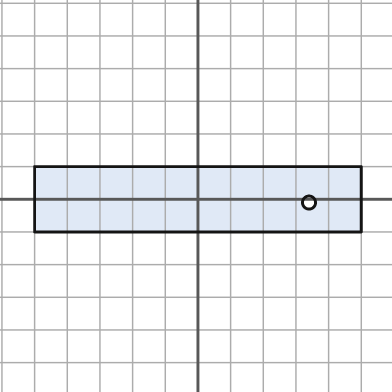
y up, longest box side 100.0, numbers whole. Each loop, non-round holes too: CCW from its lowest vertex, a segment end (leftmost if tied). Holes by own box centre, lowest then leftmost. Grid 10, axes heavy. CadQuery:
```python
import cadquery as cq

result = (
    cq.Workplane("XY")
    .moveTo(-50.0, -10.0)
    .lineTo(50.0, -10.0)
    .lineTo(50.0, 10.0)
    .lineTo(-50.0, 10.0)
    .close()
    .moveTo(34.0, -1.0)
    .circle(2.0)
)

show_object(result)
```